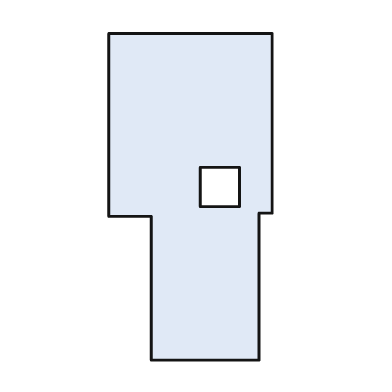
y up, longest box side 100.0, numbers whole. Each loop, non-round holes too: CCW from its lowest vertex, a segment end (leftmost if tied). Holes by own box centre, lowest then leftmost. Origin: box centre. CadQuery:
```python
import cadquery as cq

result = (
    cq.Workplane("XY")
    .moveTo(-12.0, -50.0)
    .lineTo(21.0, -50.0)
    .lineTo(21.0, -5.0)
    .lineTo(25.0, -5.0)
    .lineTo(25.0, 50.0)
    .lineTo(-25.0, 50.0)
    .lineTo(-25.0, -6.0)
    .lineTo(-12.0, -6.0)
    .close()
    .moveTo(3.0, -3.0)
    .lineTo(15.0, -3.0)
    .lineTo(15.0, 9.0)
    .lineTo(3.0, 9.0)
    .close()
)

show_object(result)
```